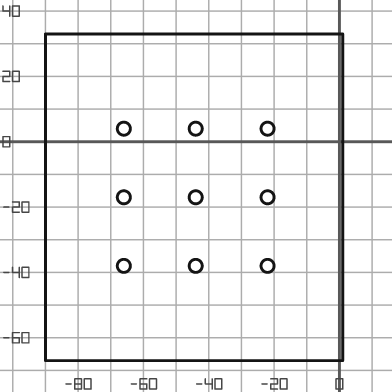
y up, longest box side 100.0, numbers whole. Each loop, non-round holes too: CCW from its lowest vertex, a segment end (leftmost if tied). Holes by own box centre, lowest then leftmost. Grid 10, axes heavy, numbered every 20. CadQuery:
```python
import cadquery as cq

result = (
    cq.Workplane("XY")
    .moveTo(-90.0, -67.0)
    .lineTo(1.0, -67.0)
    .lineTo(1.0, 33.0)
    .lineTo(-90.0, 33.0)
    .close()
    .moveTo(-66.0, -38.0)
    .circle(2.0)
    .moveTo(-44.0, -38.0)
    .circle(2.0)
    .moveTo(-22.0, -38.0)
    .circle(2.0)
    .moveTo(-66.0, -17.0)
    .circle(2.0)
    .moveTo(-44.0, -17.0)
    .circle(2.0)
    .moveTo(-22.0, -17.0)
    .circle(2.0)
    .moveTo(-66.0, 4.0)
    .circle(2.0)
    .moveTo(-44.0, 4.0)
    .circle(2.0)
    .moveTo(-22.0, 4.0)
    .circle(2.0)
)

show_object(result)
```